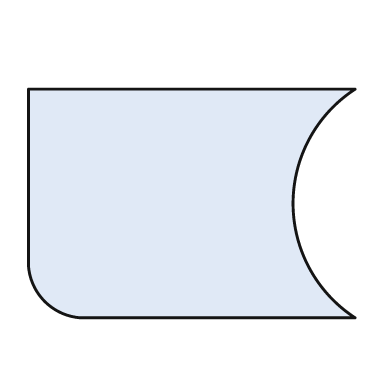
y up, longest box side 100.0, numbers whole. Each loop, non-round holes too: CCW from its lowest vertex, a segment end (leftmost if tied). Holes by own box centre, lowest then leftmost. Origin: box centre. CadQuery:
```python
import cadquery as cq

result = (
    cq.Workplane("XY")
    .moveTo(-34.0, -35.0)
    .lineTo(50.0, -35.0)
    .threePointArc((31.0, 0.0), (50.0, 35.0))
    .lineTo(-50.0, 35.0)
    .lineTo(-50.0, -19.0)
    .threePointArc((-45.0, -30.0), (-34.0, -35.0))
    .close()
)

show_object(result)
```